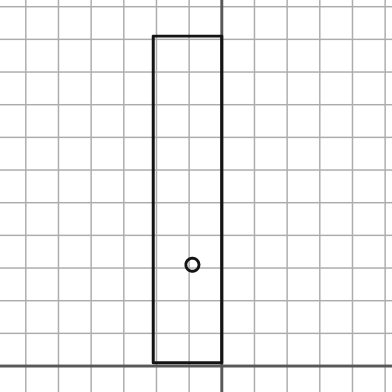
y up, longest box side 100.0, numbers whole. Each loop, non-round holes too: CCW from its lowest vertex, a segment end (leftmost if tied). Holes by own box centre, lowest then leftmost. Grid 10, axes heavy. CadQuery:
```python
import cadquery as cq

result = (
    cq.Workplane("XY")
    .moveTo(-21.0, 1.0)
    .lineTo(0.0, 1.0)
    .lineTo(0.0, 101.0)
    .lineTo(-21.0, 101.0)
    .close()
    .moveTo(-9.0, 31.0)
    .circle(2.0)
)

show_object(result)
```